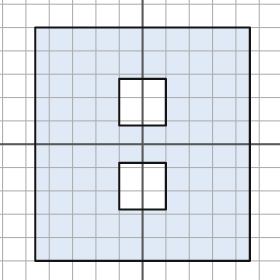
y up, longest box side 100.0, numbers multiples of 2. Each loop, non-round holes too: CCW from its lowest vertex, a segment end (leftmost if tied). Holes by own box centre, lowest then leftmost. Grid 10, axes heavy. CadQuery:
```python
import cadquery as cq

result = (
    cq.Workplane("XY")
    .moveTo(-46.0, -50.0)
    .lineTo(46.0, -50.0)
    .lineTo(46.0, 50.0)
    .lineTo(-46.0, 50.0)
    .close()
    .moveTo(-10.0, -28.0)
    .lineTo(10.0, -28.0)
    .lineTo(10.0, -8.0)
    .lineTo(-10.0, -8.0)
    .close()
    .moveTo(-10.0, 8.0)
    .lineTo(10.0, 8.0)
    .lineTo(10.0, 28.0)
    .lineTo(-10.0, 28.0)
    .close()
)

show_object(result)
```